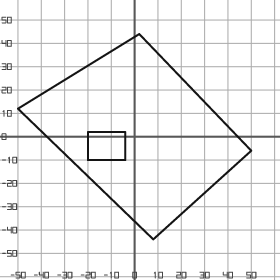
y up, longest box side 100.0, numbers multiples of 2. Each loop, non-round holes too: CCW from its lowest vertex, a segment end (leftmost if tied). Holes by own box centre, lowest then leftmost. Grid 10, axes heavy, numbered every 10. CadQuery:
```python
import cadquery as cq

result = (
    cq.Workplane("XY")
    .moveTo(8.0, -44.0)
    .lineTo(50.0, -6.0)
    .lineTo(2.0, 44.0)
    .lineTo(-50.0, 12.0)
    .close()
    .moveTo(-20.0, -10.0)
    .lineTo(-4.0, -10.0)
    .lineTo(-4.0, 2.0)
    .lineTo(-20.0, 2.0)
    .close()
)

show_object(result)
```